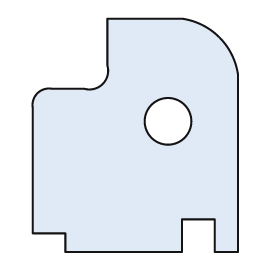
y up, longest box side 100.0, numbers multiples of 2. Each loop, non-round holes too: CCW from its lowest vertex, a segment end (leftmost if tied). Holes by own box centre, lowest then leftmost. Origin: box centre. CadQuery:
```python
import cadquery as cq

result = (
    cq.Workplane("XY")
    .moveTo(-30.0, -50.0)
    .lineTo(20.0, -50.0)
    .lineTo(20.0, -36.0)
    .lineTo(34.0, -36.0)
    .lineTo(34.0, -50.0)
    .lineTo(44.0, -50.0)
    .lineTo(44.0, 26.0)
    .threePointArc((36.0, 42.0), (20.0, 50.0))
    .lineTo(-12.0, 50.0)
    .lineTo(-12.0, 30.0)
    .threePointArc((-14.0, 22.0), (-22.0, 20.0))
    .lineTo(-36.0, 20.0)
    .threePointArc((-42.0, 18.0), (-44.0, 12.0))
    .lineTo(-44.0, -42.0)
    .lineTo(-30.0, -42.0)
    .close()
    .moveTo(14.0, 6.0)
    .circle(10.0)
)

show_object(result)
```